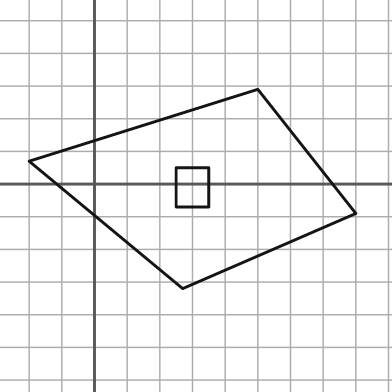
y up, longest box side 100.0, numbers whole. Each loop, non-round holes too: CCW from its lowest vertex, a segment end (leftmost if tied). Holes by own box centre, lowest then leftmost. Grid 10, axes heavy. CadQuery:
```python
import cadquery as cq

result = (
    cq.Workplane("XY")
    .moveTo(27.0, -32.0)
    .lineTo(80.0, -9.0)
    .lineTo(50.0, 29.0)
    .lineTo(-20.0, 7.0)
    .close()
    .moveTo(25.0, -7.0)
    .lineTo(35.0, -7.0)
    .lineTo(35.0, 5.0)
    .lineTo(25.0, 5.0)
    .close()
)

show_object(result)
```